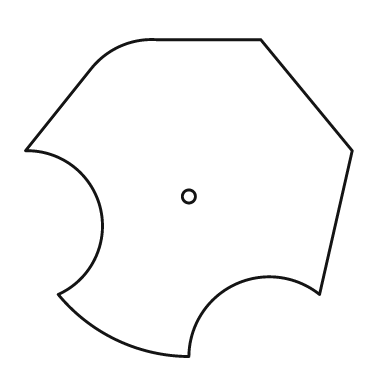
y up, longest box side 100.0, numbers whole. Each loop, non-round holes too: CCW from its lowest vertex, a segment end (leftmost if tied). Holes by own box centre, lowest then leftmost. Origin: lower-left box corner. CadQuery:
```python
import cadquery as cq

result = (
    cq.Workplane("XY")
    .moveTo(50.0, 0.0)
    .threePointArc((64.0, 22.0), (90.0, 19.0))
    .lineTo(100.0, 63.0)
    .lineTo(72.0, 97.0)
    .lineTo(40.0, 97.0)
    .threePointArc((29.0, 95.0), (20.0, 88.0))
    .lineTo(0.0, 63.0)
    .threePointArc((23.0, 45.0), (10.0, 19.0))
    .threePointArc((28.0, 5.0), (50.0, 0.0))
    .close()
    .moveTo(50.0, 49.0)
    .circle(2.0)
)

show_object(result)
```